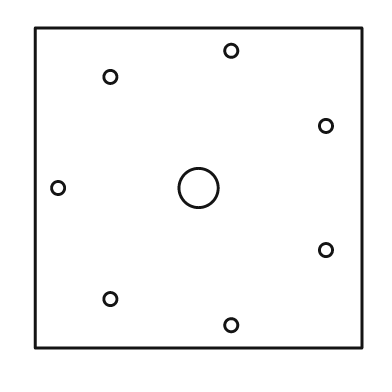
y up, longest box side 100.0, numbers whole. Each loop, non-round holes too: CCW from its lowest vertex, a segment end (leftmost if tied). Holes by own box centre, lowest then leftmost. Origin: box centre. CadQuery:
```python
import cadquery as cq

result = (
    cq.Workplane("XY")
    .moveTo(-50.0, -49.0)
    .lineTo(50.0, -49.0)
    .lineTo(50.0, 49.0)
    .lineTo(-50.0, 49.0)
    .close()
    .moveTo(10.0, -42.0)
    .circle(2.0)
    .moveTo(-27.0, -34.0)
    .circle(2.0)
    .moveTo(39.0, -19.0)
    .circle(2.0)
    .moveTo(-43.0, 0.0)
    .circle(2.0)
    .moveTo(0.0, 0.0)
    .circle(6.0)
    .moveTo(39.0, 19.0)
    .circle(2.0)
    .moveTo(-27.0, 34.0)
    .circle(2.0)
    .moveTo(10.0, 42.0)
    .circle(2.0)
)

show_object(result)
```